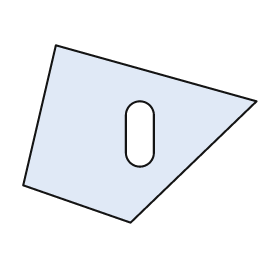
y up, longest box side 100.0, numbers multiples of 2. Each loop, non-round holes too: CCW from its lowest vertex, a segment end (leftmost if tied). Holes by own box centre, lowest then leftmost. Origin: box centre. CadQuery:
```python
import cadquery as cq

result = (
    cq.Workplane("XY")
    .moveTo(-4.0, -38.0)
    .lineTo(50.0, 14.0)
    .lineTo(-36.0, 38.0)
    .lineTo(-50.0, -22.0)
    .close()
    .moveTo(-6.0, -8.0)
    .threePointArc((0.0, -14.0), (6.0, -8.0))
    .lineTo(6.0, 8.0)
    .threePointArc((0.0, 14.0), (-6.0, 8.0))
    .close()
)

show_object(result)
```